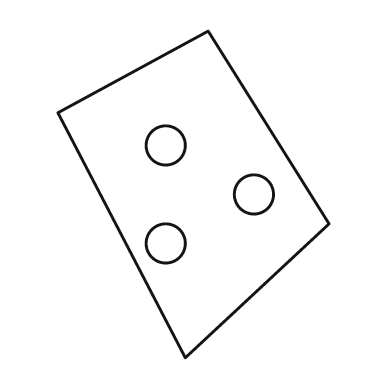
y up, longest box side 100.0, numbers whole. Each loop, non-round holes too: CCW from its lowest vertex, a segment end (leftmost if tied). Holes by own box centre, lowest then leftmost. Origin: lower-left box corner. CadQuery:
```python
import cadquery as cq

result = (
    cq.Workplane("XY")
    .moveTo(39.0, 0.0)
    .lineTo(83.0, 41.0)
    .lineTo(46.0, 100.0)
    .lineTo(0.0, 75.0)
    .close()
    .moveTo(33.0, 35.0)
    .circle(6.0)
    .moveTo(60.0, 50.0)
    .circle(6.0)
    .moveTo(33.0, 65.0)
    .circle(6.0)
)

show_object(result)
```